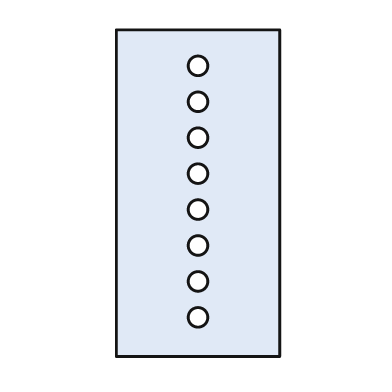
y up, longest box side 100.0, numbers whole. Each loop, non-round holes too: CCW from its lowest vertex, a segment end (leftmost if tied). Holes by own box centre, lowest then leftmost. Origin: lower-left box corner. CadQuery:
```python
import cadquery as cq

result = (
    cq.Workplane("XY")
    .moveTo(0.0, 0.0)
    .lineTo(50.0, 0.0)
    .lineTo(50.0, 100.0)
    .lineTo(0.0, 100.0)
    .close()
    .moveTo(25.0, 12.0)
    .circle(3.0)
    .moveTo(25.0, 23.0)
    .circle(3.0)
    .moveTo(25.0, 34.0)
    .circle(3.0)
    .moveTo(25.0, 45.0)
    .circle(3.0)
    .moveTo(25.0, 56.0)
    .circle(3.0)
    .moveTo(25.0, 67.0)
    .circle(3.0)
    .moveTo(25.0, 78.0)
    .circle(3.0)
    .moveTo(25.0, 89.0)
    .circle(3.0)
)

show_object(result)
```